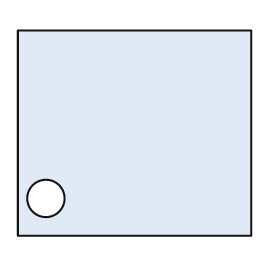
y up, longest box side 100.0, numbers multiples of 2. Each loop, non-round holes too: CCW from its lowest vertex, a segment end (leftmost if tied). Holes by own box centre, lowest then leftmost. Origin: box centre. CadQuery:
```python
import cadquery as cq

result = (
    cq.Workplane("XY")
    .moveTo(-50.0, -44.0)
    .lineTo(50.0, -44.0)
    .lineTo(50.0, 44.0)
    .lineTo(-50.0, 44.0)
    .close()
    .moveTo(-38.0, -28.0)
    .circle(8.0)
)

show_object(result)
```